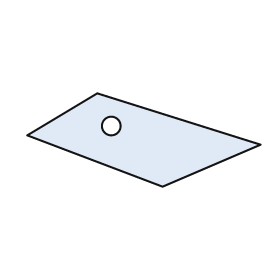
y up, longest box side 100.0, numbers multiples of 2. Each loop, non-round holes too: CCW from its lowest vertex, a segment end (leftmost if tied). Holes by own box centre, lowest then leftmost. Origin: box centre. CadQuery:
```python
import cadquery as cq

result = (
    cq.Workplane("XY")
    .moveTo(8.0, -20.0)
    .lineTo(50.0, -2.0)
    .lineTo(-20.0, 20.0)
    .lineTo(-50.0, 2.0)
    .close()
    .moveTo(-14.0, 6.0)
    .circle(4.0)
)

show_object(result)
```